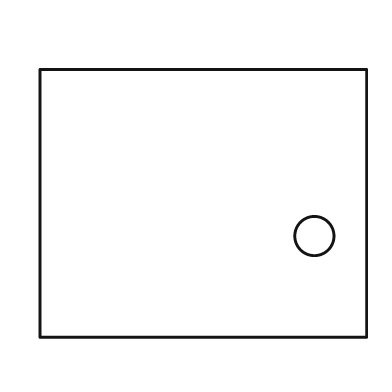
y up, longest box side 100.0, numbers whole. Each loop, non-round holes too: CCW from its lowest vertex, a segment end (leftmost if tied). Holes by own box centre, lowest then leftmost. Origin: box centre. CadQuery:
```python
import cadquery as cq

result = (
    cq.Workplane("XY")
    .moveTo(-50.0, -41.0)
    .lineTo(50.0, -41.0)
    .lineTo(50.0, 41.0)
    .lineTo(-50.0, 41.0)
    .close()
    .moveTo(34.0, -10.0)
    .circle(6.0)
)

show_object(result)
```